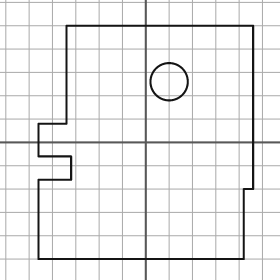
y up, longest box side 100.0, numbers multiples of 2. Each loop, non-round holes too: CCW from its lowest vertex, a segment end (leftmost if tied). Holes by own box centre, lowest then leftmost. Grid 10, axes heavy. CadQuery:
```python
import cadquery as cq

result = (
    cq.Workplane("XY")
    .moveTo(-46.0, -50.0)
    .lineTo(42.0, -50.0)
    .lineTo(42.0, -20.0)
    .lineTo(46.0, -20.0)
    .lineTo(46.0, 50.0)
    .lineTo(-34.0, 50.0)
    .lineTo(-34.0, 8.0)
    .lineTo(-46.0, 8.0)
    .lineTo(-46.0, -6.0)
    .lineTo(-32.0, -6.0)
    .lineTo(-32.0, -16.0)
    .lineTo(-46.0, -16.0)
    .close()
    .moveTo(10.0, 26.0)
    .circle(8.0)
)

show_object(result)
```